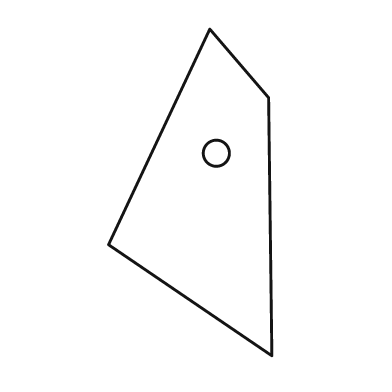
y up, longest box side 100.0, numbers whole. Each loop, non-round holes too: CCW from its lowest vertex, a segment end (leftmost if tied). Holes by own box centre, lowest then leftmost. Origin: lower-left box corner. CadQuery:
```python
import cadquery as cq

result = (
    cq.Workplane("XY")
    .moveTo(50.0, 0.0)
    .lineTo(49.0, 79.0)
    .lineTo(31.0, 100.0)
    .lineTo(0.0, 34.0)
    .close()
    .moveTo(33.0, 62.0)
    .circle(4.0)
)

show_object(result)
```